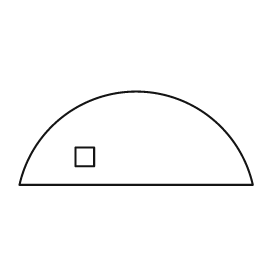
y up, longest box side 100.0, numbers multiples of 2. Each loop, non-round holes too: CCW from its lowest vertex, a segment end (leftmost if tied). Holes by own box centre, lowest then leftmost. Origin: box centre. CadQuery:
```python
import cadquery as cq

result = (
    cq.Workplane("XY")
    .moveTo(-50.0, -20.0)
    .lineTo(50.0, -20.0)
    .threePointArc((0.0, 20.0), (-50.0, -20.0))
    .close()
    .moveTo(-26.0, -12.0)
    .lineTo(-18.0, -12.0)
    .lineTo(-18.0, -4.0)
    .lineTo(-26.0, -4.0)
    .close()
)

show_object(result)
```